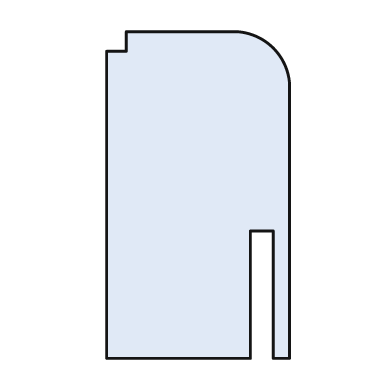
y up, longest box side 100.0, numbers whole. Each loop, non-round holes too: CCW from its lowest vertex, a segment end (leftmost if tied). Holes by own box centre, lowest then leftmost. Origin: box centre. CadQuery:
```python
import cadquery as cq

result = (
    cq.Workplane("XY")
    .moveTo(-28.0, -50.0)
    .lineTo(16.0, -50.0)
    .lineTo(16.0, -11.0)
    .lineTo(23.0, -11.0)
    .lineTo(23.0, -50.0)
    .lineTo(28.0, -50.0)
    .lineTo(28.0, 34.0)
    .threePointArc((23.0, 45.0), (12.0, 50.0))
    .lineTo(-22.0, 50.0)
    .lineTo(-22.0, 44.0)
    .lineTo(-28.0, 44.0)
    .close()
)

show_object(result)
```